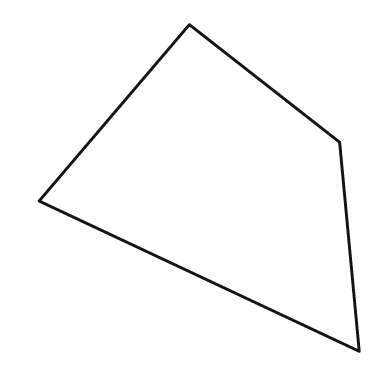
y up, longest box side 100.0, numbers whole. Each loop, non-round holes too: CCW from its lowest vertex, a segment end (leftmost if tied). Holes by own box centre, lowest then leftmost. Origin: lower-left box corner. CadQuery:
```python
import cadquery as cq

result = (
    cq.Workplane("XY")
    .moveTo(98.0, 0.0)
    .lineTo(92.0, 64.0)
    .lineTo(46.0, 100.0)
    .lineTo(0.0, 46.0)
    .close()
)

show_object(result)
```